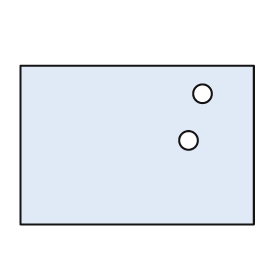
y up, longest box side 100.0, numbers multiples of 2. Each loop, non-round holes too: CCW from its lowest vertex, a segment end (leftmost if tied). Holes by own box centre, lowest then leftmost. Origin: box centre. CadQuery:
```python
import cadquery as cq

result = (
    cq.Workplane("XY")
    .moveTo(-50.0, -34.0)
    .lineTo(50.0, -34.0)
    .lineTo(50.0, 34.0)
    .lineTo(-50.0, 34.0)
    .close()
    .moveTo(22.0, 2.0)
    .circle(4.0)
    .moveTo(28.0, 22.0)
    .circle(4.0)
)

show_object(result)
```